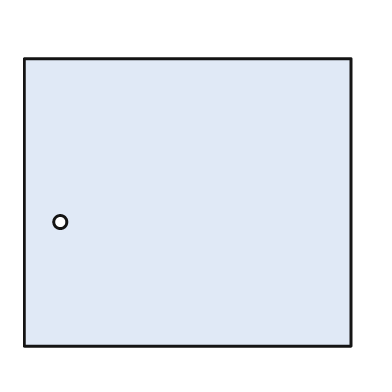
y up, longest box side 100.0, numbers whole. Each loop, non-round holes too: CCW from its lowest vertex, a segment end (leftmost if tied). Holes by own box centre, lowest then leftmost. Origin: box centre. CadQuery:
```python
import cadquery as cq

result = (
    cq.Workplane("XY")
    .moveTo(-50.0, -44.0)
    .lineTo(50.0, -44.0)
    .lineTo(50.0, 44.0)
    .lineTo(-50.0, 44.0)
    .close()
    .moveTo(-39.0, -6.0)
    .circle(2.0)
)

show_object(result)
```